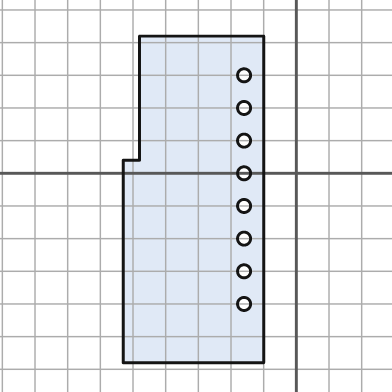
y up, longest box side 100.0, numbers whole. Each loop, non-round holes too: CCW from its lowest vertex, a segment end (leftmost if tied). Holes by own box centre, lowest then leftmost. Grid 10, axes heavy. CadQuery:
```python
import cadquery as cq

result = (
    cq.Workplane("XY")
    .moveTo(-53.0, -58.0)
    .lineTo(-10.0, -58.0)
    .lineTo(-10.0, 42.0)
    .lineTo(-48.0, 42.0)
    .lineTo(-48.0, 4.0)
    .lineTo(-53.0, 4.0)
    .close()
    .moveTo(-16.0, -40.0)
    .circle(2.0)
    .moveTo(-16.0, -30.0)
    .circle(2.0)
    .moveTo(-16.0, -20.0)
    .circle(2.0)
    .moveTo(-16.0, -10.0)
    .circle(2.0)
    .moveTo(-16.0, 0.0)
    .circle(2.0)
    .moveTo(-16.0, 10.0)
    .circle(2.0)
    .moveTo(-16.0, 20.0)
    .circle(2.0)
    .moveTo(-16.0, 30.0)
    .circle(2.0)
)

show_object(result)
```